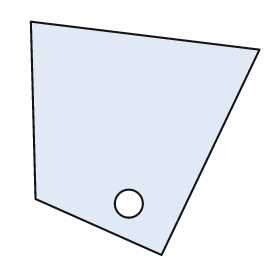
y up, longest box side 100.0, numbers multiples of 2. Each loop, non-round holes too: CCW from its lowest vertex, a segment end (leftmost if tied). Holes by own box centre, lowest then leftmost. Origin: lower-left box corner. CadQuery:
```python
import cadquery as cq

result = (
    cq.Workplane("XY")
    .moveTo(56.0, 0.0)
    .lineTo(98.0, 88.0)
    .lineTo(0.0, 100.0)
    .lineTo(2.0, 24.0)
    .close()
    .moveTo(42.0, 22.0)
    .circle(6.0)
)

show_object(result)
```